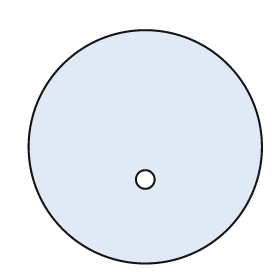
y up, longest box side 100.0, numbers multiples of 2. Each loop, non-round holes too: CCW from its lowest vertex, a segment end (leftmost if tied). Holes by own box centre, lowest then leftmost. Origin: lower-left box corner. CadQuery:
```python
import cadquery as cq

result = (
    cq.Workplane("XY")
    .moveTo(50.0, 50.0)
    .circle(50.0)
    .moveTo(50.0, 36.0)
    .circle(4.0)
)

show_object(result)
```